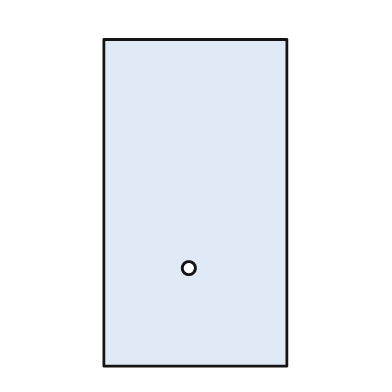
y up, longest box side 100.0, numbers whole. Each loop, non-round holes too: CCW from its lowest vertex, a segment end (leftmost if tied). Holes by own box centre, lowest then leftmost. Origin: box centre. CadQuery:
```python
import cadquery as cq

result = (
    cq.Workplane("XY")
    .moveTo(-28.0, -50.0)
    .lineTo(28.0, -50.0)
    .lineTo(28.0, 50.0)
    .lineTo(-28.0, 50.0)
    .close()
    .moveTo(-2.0, -20.0)
    .circle(2.0)
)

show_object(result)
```